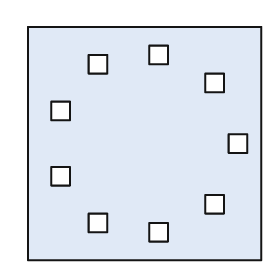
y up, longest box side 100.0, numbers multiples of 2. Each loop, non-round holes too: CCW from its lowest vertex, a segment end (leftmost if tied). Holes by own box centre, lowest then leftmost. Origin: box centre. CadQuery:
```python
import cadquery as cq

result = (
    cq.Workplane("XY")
    .moveTo(-50.0, -50.0)
    .lineTo(50.0, -50.0)
    .lineTo(50.0, 50.0)
    .lineTo(-50.0, 50.0)
    .close()
    .moveTo(2.0, -42.0)
    .lineTo(10.0, -42.0)
    .lineTo(10.0, -34.0)
    .lineTo(2.0, -34.0)
    .close()
    .moveTo(-24.0, -38.0)
    .lineTo(-16.0, -38.0)
    .lineTo(-16.0, -30.0)
    .lineTo(-24.0, -30.0)
    .close()
    .moveTo(26.0, -30.0)
    .lineTo(34.0, -30.0)
    .lineTo(34.0, -22.0)
    .lineTo(26.0, -22.0)
    .close()
    .moveTo(-40.0, -18.0)
    .lineTo(-32.0, -18.0)
    .lineTo(-32.0, -10.0)
    .lineTo(-40.0, -10.0)
    .close()
    .moveTo(36.0, -4.0)
    .lineTo(44.0, -4.0)
    .lineTo(44.0, 4.0)
    .lineTo(36.0, 4.0)
    .close()
    .moveTo(-40.0, 10.0)
    .lineTo(-32.0, 10.0)
    .lineTo(-32.0, 18.0)
    .lineTo(-40.0, 18.0)
    .close()
    .moveTo(26.0, 22.0)
    .lineTo(34.0, 22.0)
    .lineTo(34.0, 30.0)
    .lineTo(26.0, 30.0)
    .close()
    .moveTo(-24.0, 30.0)
    .lineTo(-16.0, 30.0)
    .lineTo(-16.0, 38.0)
    .lineTo(-24.0, 38.0)
    .close()
    .moveTo(2.0, 34.0)
    .lineTo(10.0, 34.0)
    .lineTo(10.0, 42.0)
    .lineTo(2.0, 42.0)
    .close()
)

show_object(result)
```